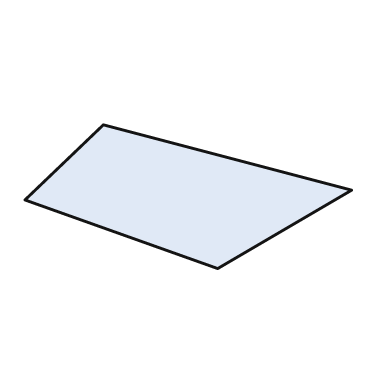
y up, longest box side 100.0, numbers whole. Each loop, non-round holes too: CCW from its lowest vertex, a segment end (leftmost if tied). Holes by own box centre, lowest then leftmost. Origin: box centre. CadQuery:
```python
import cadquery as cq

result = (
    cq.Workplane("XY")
    .moveTo(9.0, -22.0)
    .lineTo(50.0, 2.0)
    .lineTo(-26.0, 22.0)
    .lineTo(-50.0, -1.0)
    .close()
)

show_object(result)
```